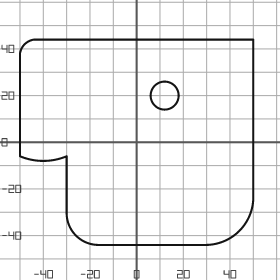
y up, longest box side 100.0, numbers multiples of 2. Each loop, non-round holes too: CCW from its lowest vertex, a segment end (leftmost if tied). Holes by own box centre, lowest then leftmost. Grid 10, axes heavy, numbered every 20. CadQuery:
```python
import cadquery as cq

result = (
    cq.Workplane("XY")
    .moveTo(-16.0, -44.0)
    .lineTo(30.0, -44.0)
    .threePointArc((44.0, -38.0), (50.0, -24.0))
    .lineTo(50.0, 44.0)
    .lineTo(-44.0, 44.0)
    .threePointArc((-48.0, 42.0), (-50.0, 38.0))
    .lineTo(-50.0, -6.0)
    .threePointArc((-40.0, -8.0), (-30.0, -6.0))
    .lineTo(-30.0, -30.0)
    .threePointArc((-26.0, -40.0), (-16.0, -44.0))
    .close()
    .moveTo(12.0, 20.0)
    .circle(6.0)
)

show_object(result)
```